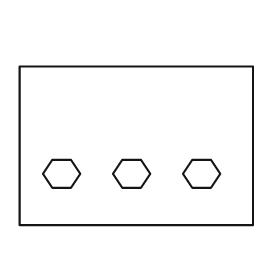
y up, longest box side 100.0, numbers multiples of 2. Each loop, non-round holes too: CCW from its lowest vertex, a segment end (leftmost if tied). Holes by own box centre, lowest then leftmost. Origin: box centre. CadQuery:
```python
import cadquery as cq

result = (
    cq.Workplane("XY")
    .moveTo(-50.0, -34.0)
    .lineTo(50.0, -34.0)
    .lineTo(50.0, 34.0)
    .lineTo(-50.0, 34.0)
    .close()
    .moveTo(-36.0, -18.0)
    .lineTo(-28.0, -18.0)
    .lineTo(-24.0, -12.0)
    .lineTo(-28.0, -6.0)
    .lineTo(-36.0, -6.0)
    .lineTo(-40.0, -12.0)
    .close()
    .moveTo(-6.0, -18.0)
    .lineTo(2.0, -18.0)
    .lineTo(6.0, -12.0)
    .lineTo(2.0, -6.0)
    .lineTo(-6.0, -6.0)
    .lineTo(-10.0, -12.0)
    .close()
    .moveTo(24.0, -18.0)
    .lineTo(32.0, -18.0)
    .lineTo(36.0, -12.0)
    .lineTo(32.0, -6.0)
    .lineTo(24.0, -6.0)
    .lineTo(20.0, -12.0)
    .close()
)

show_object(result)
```